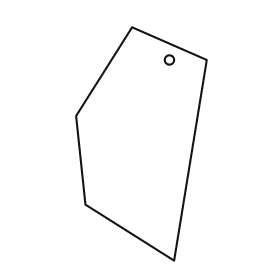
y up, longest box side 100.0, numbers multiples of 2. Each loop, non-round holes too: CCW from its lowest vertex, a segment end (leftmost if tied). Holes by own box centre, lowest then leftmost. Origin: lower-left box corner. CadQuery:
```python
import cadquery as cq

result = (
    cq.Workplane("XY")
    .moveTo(42.0, 0.0)
    .lineTo(56.0, 86.0)
    .lineTo(24.0, 100.0)
    .lineTo(0.0, 62.0)
    .lineTo(4.0, 24.0)
    .close()
    .moveTo(40.0, 86.0)
    .circle(2.0)
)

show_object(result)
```